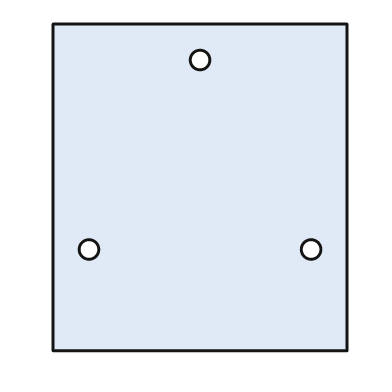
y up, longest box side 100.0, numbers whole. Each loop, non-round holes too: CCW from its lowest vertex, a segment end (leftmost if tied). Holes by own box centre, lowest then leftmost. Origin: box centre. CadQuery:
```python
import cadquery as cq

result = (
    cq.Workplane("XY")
    .moveTo(-45.0, -50.0)
    .lineTo(45.0, -50.0)
    .lineTo(45.0, 50.0)
    .lineTo(-45.0, 50.0)
    .close()
    .moveTo(-34.0, -19.0)
    .circle(3.0)
    .moveTo(34.0, -19.0)
    .circle(3.0)
    .moveTo(0.0, 39.0)
    .circle(3.0)
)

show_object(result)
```